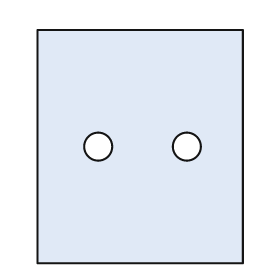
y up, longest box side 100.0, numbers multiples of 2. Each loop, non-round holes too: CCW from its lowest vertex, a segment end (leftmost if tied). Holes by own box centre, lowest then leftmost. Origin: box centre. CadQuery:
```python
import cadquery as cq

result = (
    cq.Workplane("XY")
    .moveTo(-44.0, -50.0)
    .lineTo(44.0, -50.0)
    .lineTo(44.0, 50.0)
    .lineTo(-44.0, 50.0)
    .close()
    .moveTo(-18.0, 0.0)
    .circle(6.0)
    .moveTo(20.0, 0.0)
    .circle(6.0)
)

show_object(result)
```